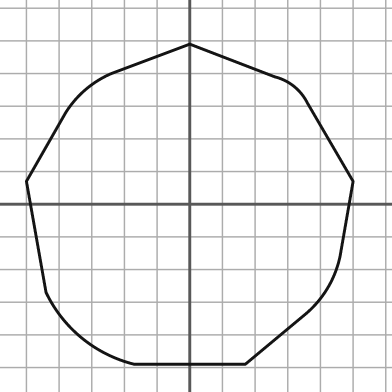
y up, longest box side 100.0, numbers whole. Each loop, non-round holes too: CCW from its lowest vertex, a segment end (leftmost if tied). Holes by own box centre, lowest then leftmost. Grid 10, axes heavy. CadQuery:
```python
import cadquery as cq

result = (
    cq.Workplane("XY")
    .moveTo(-17.0, -49.0)
    .lineTo(17.0, -49.0)
    .lineTo(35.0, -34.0)
    .threePointArc((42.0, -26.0), (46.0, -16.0))
    .lineTo(50.0, 7.0)
    .lineTo(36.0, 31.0)
    .threePointArc((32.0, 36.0), (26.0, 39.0))
    .lineTo(0.0, 49.0)
    .lineTo(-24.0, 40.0)
    .threePointArc((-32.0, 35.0), (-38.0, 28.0))
    .lineTo(-50.0, 7.0)
    .lineTo(-44.0, -27.0)
    .threePointArc((-33.0, -41.0), (-17.0, -49.0))
    .close()
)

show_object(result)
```